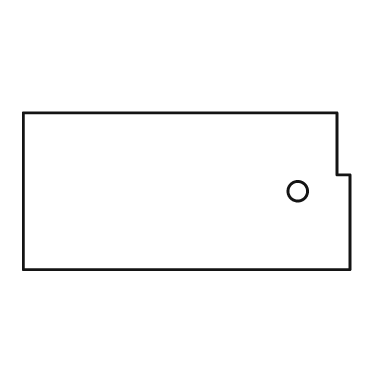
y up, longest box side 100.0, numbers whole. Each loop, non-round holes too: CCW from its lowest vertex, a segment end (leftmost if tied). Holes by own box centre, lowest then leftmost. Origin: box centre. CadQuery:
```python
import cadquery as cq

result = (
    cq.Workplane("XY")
    .moveTo(-50.0, -24.0)
    .lineTo(50.0, -24.0)
    .lineTo(50.0, 5.0)
    .lineTo(46.0, 5.0)
    .lineTo(46.0, 24.0)
    .lineTo(-50.0, 24.0)
    .close()
    .moveTo(34.0, 0.0)
    .circle(3.0)
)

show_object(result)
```